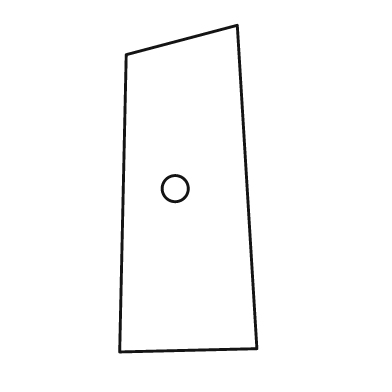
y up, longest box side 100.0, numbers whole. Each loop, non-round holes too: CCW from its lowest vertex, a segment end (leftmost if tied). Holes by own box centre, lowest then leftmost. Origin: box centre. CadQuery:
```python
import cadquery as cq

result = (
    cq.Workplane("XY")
    .moveTo(-21.0, -50.0)
    .lineTo(21.0, -49.0)
    .lineTo(15.0, 50.0)
    .lineTo(-19.0, 41.0)
    .close()
    .moveTo(-4.0, 0.0)
    .circle(4.0)
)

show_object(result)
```